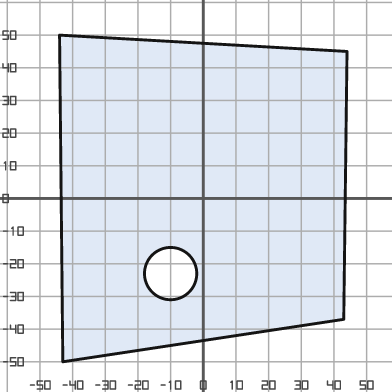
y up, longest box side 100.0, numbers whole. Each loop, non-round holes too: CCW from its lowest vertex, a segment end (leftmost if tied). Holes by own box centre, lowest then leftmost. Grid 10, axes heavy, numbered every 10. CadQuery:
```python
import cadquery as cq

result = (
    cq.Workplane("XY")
    .moveTo(-43.0, -50.0)
    .lineTo(43.0, -37.0)
    .lineTo(44.0, 45.0)
    .lineTo(-44.0, 50.0)
    .close()
    .moveTo(-10.0, -23.0)
    .circle(8.0)
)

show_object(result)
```